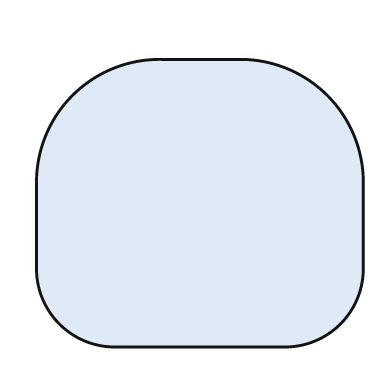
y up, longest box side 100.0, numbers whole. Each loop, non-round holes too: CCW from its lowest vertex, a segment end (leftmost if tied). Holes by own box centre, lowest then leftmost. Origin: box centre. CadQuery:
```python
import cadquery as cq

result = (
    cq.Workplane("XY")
    .moveTo(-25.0, -44.0)
    .lineTo(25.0, -44.0)
    .threePointArc((43.0, -37.0), (50.0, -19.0))
    .lineTo(50.0, 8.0)
    .threePointArc((39.0, 33.0), (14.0, 44.0))
    .lineTo(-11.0, 44.0)
    .threePointArc((-39.0, 33.0), (-50.0, 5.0))
    .lineTo(-50.0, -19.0)
    .threePointArc((-43.0, -37.0), (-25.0, -44.0))
    .close()
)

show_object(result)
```